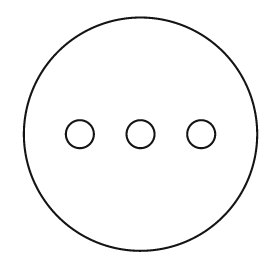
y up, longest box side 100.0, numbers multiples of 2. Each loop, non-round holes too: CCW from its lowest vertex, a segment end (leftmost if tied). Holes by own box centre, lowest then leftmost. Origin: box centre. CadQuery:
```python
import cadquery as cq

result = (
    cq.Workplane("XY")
    .moveTo(0.0, 0.0)
    .circle(50.0)
    .moveTo(-26.0, 0.0)
    .circle(6.0)
    .moveTo(0.0, 0.0)
    .circle(6.0)
    .moveTo(26.0, 0.0)
    .circle(6.0)
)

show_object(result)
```